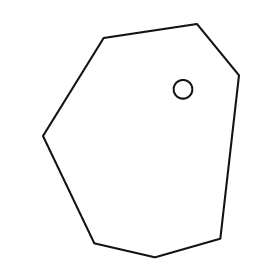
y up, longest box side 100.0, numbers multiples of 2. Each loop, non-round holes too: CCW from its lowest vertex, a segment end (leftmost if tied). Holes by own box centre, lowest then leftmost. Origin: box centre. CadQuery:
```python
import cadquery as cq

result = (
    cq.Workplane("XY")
    .moveTo(6.0, -50.0)
    .lineTo(34.0, -42.0)
    .lineTo(42.0, 28.0)
    .lineTo(24.0, 50.0)
    .lineTo(-16.0, 44.0)
    .lineTo(-42.0, 2.0)
    .lineTo(-20.0, -44.0)
    .close()
    .moveTo(18.0, 22.0)
    .circle(4.0)
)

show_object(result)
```